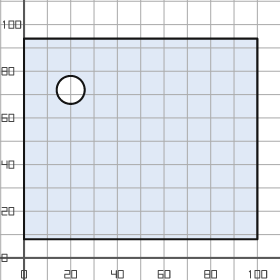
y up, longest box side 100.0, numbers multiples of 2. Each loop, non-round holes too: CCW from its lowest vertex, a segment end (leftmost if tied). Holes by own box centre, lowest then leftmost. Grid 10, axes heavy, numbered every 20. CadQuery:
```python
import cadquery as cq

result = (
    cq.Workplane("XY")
    .moveTo(0.0, 8.0)
    .lineTo(100.0, 8.0)
    .lineTo(100.0, 94.0)
    .lineTo(0.0, 94.0)
    .close()
    .moveTo(20.0, 72.0)
    .circle(6.0)
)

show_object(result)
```